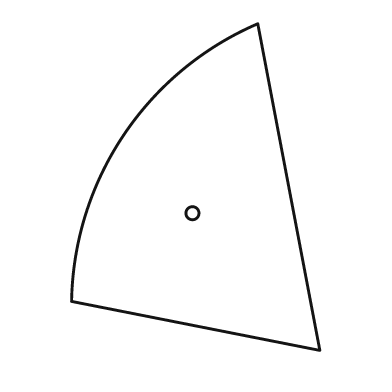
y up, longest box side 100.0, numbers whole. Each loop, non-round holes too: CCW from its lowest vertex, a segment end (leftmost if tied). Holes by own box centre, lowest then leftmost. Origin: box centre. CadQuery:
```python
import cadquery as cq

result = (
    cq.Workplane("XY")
    .moveTo(38.0, -50.0)
    .lineTo(19.0, 50.0)
    .threePointArc((-22.0, 16.0), (-38.0, -35.0))
    .close()
    .moveTo(-1.0, -8.0)
    .circle(2.0)
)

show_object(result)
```